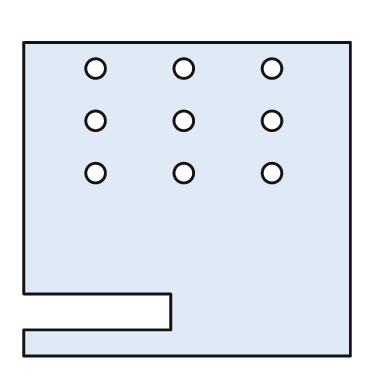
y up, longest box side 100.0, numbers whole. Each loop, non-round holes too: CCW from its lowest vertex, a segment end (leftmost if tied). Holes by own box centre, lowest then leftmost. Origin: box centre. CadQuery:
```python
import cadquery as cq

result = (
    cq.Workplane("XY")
    .moveTo(-50.0, -48.0)
    .lineTo(50.0, -48.0)
    .lineTo(50.0, 48.0)
    .lineTo(-50.0, 48.0)
    .lineTo(-50.0, -29.0)
    .lineTo(-5.0, -29.0)
    .lineTo(-5.0, -40.0)
    .lineTo(-50.0, -40.0)
    .close()
    .moveTo(-28.0, 8.0)
    .circle(3.0)
    .moveTo(-1.0, 8.0)
    .circle(3.0)
    .moveTo(26.0, 8.0)
    .circle(3.0)
    .moveTo(-28.0, 24.0)
    .circle(3.0)
    .moveTo(-1.0, 24.0)
    .circle(3.0)
    .moveTo(26.0, 24.0)
    .circle(3.0)
    .moveTo(-28.0, 40.0)
    .circle(3.0)
    .moveTo(-1.0, 40.0)
    .circle(3.0)
    .moveTo(26.0, 40.0)
    .circle(3.0)
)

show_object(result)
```